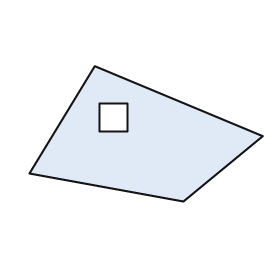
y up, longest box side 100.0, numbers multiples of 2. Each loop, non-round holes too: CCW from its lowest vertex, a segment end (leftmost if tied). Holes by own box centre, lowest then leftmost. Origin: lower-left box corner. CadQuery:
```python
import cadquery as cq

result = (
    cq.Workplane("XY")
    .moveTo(66.0, 0.0)
    .lineTo(100.0, 28.0)
    .lineTo(28.0, 58.0)
    .lineTo(0.0, 12.0)
    .close()
    .moveTo(30.0, 30.0)
    .lineTo(42.0, 30.0)
    .lineTo(42.0, 42.0)
    .lineTo(30.0, 42.0)
    .close()
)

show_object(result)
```